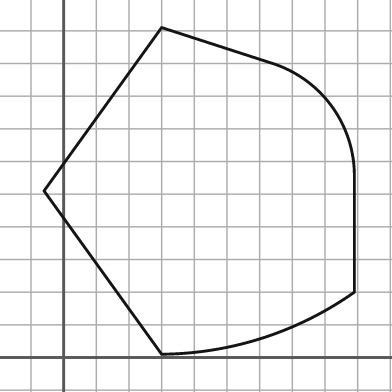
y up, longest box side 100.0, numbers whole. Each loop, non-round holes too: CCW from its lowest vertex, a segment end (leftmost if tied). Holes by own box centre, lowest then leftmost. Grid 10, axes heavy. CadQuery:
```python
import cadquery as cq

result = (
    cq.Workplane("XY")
    .moveTo(30.0, 1.0)
    .threePointArc((61.0, 6.0), (89.0, 20.0))
    .lineTo(89.0, 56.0)
    .threePointArc((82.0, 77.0), (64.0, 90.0))
    .lineTo(30.0, 101.0)
    .lineTo(-6.0, 51.0)
    .close()
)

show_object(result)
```